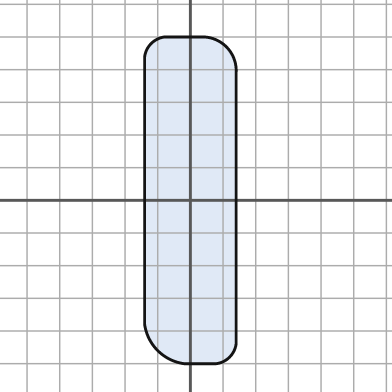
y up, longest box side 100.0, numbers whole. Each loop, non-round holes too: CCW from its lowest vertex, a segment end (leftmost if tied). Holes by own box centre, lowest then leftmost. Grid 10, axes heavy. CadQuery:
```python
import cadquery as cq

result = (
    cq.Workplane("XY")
    .moveTo(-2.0, -50.0)
    .lineTo(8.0, -50.0)
    .threePointArc((12.0, -48.0), (14.0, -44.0))
    .lineTo(14.0, 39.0)
    .threePointArc((11.0, 47.0), (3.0, 50.0))
    .lineTo(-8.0, 50.0)
    .threePointArc((-12.0, 48.0), (-14.0, 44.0))
    .lineTo(-14.0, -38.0)
    .threePointArc((-10.0, -46.0), (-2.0, -50.0))
    .close()
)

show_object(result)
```